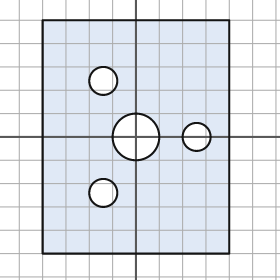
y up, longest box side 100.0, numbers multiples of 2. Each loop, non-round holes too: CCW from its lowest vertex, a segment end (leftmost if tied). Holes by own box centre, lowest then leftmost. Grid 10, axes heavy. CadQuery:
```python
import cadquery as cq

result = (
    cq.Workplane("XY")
    .moveTo(-40.0, -50.0)
    .lineTo(40.0, -50.0)
    .lineTo(40.0, 50.0)
    .lineTo(-40.0, 50.0)
    .close()
    .moveTo(-14.0, -24.0)
    .circle(6.0)
    .moveTo(0.0, 0.0)
    .circle(10.0)
    .moveTo(26.0, 0.0)
    .circle(6.0)
    .moveTo(-14.0, 24.0)
    .circle(6.0)
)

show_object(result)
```